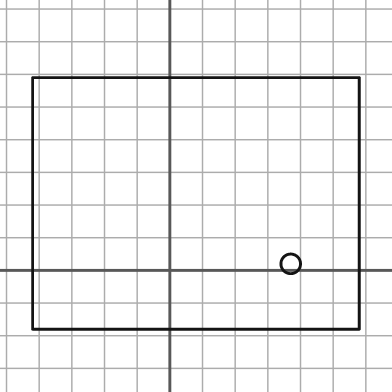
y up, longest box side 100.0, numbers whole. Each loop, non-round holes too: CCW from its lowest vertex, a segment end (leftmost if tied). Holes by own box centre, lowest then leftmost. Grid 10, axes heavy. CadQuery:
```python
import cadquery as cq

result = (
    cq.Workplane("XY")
    .moveTo(-42.0, -18.0)
    .lineTo(58.0, -18.0)
    .lineTo(58.0, 59.0)
    .lineTo(-42.0, 59.0)
    .close()
    .moveTo(37.0, 2.0)
    .circle(3.0)
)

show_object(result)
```